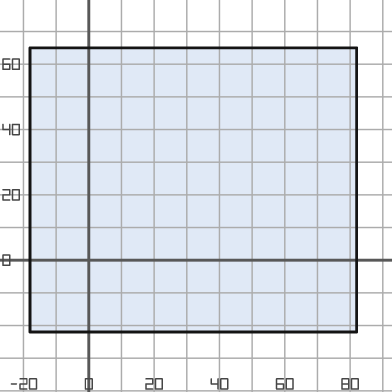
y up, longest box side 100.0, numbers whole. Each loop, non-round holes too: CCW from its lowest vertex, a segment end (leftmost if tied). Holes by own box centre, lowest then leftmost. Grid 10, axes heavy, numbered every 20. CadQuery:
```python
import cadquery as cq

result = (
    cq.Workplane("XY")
    .moveTo(-18.0, -22.0)
    .lineTo(82.0, -22.0)
    .lineTo(82.0, 65.0)
    .lineTo(-18.0, 65.0)
    .close()
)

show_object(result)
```